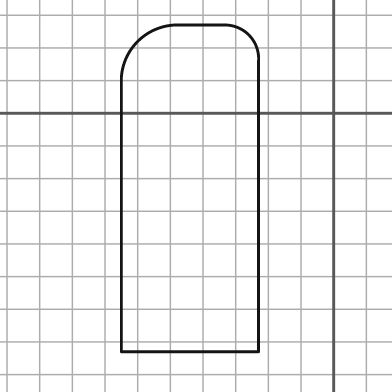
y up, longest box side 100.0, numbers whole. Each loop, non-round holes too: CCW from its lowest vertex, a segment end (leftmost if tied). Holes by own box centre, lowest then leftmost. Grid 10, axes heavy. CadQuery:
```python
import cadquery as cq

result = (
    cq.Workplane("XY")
    .moveTo(-65.0, -73.0)
    .lineTo(-23.0, -73.0)
    .lineTo(-23.0, 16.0)
    .threePointArc((-26.0, 24.0), (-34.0, 27.0))
    .lineTo(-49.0, 27.0)
    .threePointArc((-60.0, 22.0), (-65.0, 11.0))
    .close()
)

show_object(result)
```